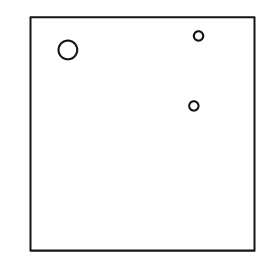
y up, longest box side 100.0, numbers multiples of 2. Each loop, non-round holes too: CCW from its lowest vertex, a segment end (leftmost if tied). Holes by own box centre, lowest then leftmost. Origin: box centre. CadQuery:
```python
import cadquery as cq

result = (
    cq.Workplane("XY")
    .moveTo(-48.0, -50.0)
    .lineTo(48.0, -50.0)
    .lineTo(48.0, 50.0)
    .lineTo(-48.0, 50.0)
    .close()
    .moveTo(22.0, 12.0)
    .circle(2.0)
    .moveTo(-32.0, 36.0)
    .circle(4.0)
    .moveTo(24.0, 42.0)
    .circle(2.0)
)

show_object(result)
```